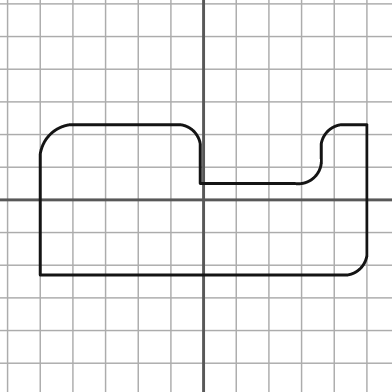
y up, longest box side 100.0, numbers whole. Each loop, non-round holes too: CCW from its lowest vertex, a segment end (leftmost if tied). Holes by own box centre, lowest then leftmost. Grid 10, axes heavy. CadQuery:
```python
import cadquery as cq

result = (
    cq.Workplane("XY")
    .moveTo(-50.0, -23.0)
    .lineTo(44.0, -23.0)
    .threePointArc((48.0, -21.0), (50.0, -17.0))
    .lineTo(50.0, 23.0)
    .lineTo(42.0, 23.0)
    .threePointArc((38.0, 21.0), (36.0, 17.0))
    .lineTo(36.0, 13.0)
    .threePointArc((34.0, 7.0), (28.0, 5.0))
    .lineTo(-1.0, 5.0)
    .lineTo(-1.0, 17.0)
    .threePointArc((-3.0, 21.0), (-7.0, 23.0))
    .lineTo(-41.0, 23.0)
    .threePointArc((-47.0, 20.0), (-50.0, 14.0))
    .close()
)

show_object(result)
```